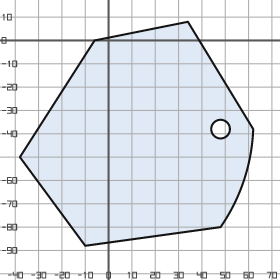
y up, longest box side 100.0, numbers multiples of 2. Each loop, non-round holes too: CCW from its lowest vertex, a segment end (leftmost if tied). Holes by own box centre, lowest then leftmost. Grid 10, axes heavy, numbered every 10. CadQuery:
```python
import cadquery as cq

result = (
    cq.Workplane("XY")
    .moveTo(-10.0, -88.0)
    .lineTo(48.0, -80.0)
    .threePointArc((58.0, -60.0), (62.0, -38.0))
    .lineTo(34.0, 8.0)
    .lineTo(-6.0, 0.0)
    .lineTo(-38.0, -50.0)
    .close()
    .moveTo(48.0, -38.0)
    .circle(4.0)
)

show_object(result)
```